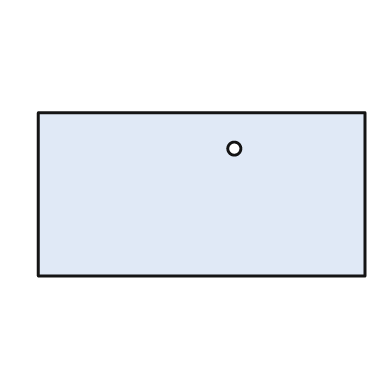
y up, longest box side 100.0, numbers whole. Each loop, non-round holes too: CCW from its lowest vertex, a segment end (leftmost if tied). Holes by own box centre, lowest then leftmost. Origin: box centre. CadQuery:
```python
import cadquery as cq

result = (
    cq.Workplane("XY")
    .moveTo(-50.0, -25.0)
    .lineTo(50.0, -25.0)
    .lineTo(50.0, 25.0)
    .lineTo(-50.0, 25.0)
    .close()
    .moveTo(10.0, 14.0)
    .circle(2.0)
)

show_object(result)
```